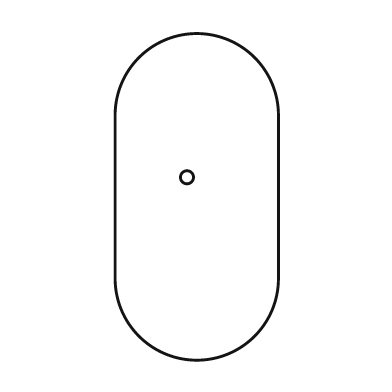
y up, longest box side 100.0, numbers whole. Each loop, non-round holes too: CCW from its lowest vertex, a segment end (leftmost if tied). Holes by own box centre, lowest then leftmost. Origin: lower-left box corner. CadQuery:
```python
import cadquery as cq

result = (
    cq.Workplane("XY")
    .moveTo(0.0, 25.0)
    .threePointArc((25.0, 0.0), (50.0, 25.0))
    .lineTo(50.0, 75.0)
    .threePointArc((25.0, 100.0), (0.0, 75.0))
    .close()
    .moveTo(22.0, 56.0)
    .circle(2.0)
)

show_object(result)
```